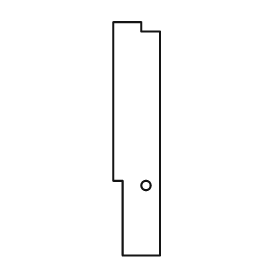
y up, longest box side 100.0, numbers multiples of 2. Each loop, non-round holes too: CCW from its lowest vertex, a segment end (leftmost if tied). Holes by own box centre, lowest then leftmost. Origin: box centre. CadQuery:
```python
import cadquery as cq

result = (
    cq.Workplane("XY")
    .moveTo(-6.0, -50.0)
    .lineTo(10.0, -50.0)
    .lineTo(10.0, 46.0)
    .lineTo(2.0, 46.0)
    .lineTo(2.0, 50.0)
    .lineTo(-10.0, 50.0)
    .lineTo(-10.0, -18.0)
    .lineTo(-6.0, -18.0)
    .close()
    .moveTo(4.0, -20.0)
    .circle(2.0)
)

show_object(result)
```